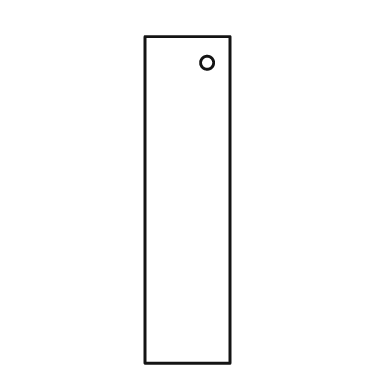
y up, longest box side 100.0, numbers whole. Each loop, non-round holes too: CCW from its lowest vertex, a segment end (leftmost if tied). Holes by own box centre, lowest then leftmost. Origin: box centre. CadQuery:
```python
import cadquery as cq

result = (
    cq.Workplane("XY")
    .moveTo(-13.0, -50.0)
    .lineTo(13.0, -50.0)
    .lineTo(13.0, 50.0)
    .lineTo(-13.0, 50.0)
    .close()
    .moveTo(6.0, 42.0)
    .circle(2.0)
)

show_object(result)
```